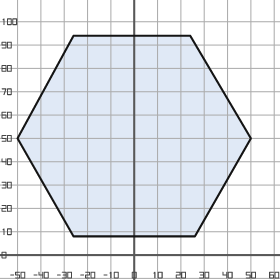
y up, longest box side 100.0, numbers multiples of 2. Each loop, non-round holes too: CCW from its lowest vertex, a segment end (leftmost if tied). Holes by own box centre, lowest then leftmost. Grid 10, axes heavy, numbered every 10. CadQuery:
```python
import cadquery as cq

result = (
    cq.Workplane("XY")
    .moveTo(-26.0, 8.0)
    .lineTo(26.0, 8.0)
    .lineTo(50.0, 50.0)
    .lineTo(24.0, 94.0)
    .lineTo(-26.0, 94.0)
    .lineTo(-50.0, 50.0)
    .close()
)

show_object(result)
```